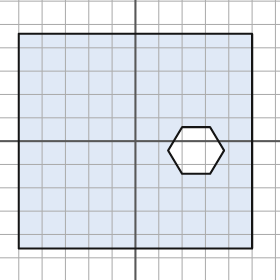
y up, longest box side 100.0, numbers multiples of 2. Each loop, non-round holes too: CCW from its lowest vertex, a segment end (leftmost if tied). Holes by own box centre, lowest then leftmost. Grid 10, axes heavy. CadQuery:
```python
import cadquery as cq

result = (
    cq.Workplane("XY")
    .moveTo(-50.0, -46.0)
    .lineTo(50.0, -46.0)
    .lineTo(50.0, 46.0)
    .lineTo(-50.0, 46.0)
    .close()
    .moveTo(20.0, -14.0)
    .lineTo(32.0, -14.0)
    .lineTo(38.0, -4.0)
    .lineTo(32.0, 6.0)
    .lineTo(20.0, 6.0)
    .lineTo(14.0, -4.0)
    .close()
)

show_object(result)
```